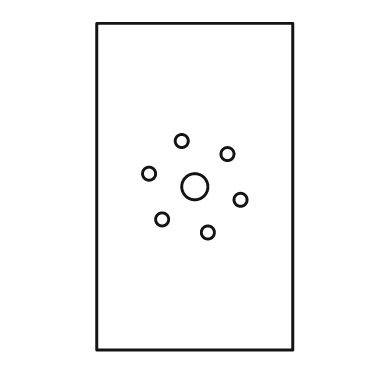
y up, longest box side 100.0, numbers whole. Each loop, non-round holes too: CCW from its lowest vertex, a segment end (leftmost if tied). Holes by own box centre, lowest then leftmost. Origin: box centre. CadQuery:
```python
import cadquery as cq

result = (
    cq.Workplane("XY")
    .moveTo(-30.0, -50.0)
    .lineTo(30.0, -50.0)
    .lineTo(30.0, 50.0)
    .lineTo(-30.0, 50.0)
    .close()
    .moveTo(4.0, -14.0)
    .circle(2.0)
    .moveTo(-10.0, -10.0)
    .circle(2.0)
    .moveTo(14.0, -4.0)
    .circle(2.0)
    .moveTo(0.0, 0.0)
    .circle(4.0)
    .moveTo(-14.0, 4.0)
    .circle(2.0)
    .moveTo(10.0, 10.0)
    .circle(2.0)
    .moveTo(-4.0, 14.0)
    .circle(2.0)
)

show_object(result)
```